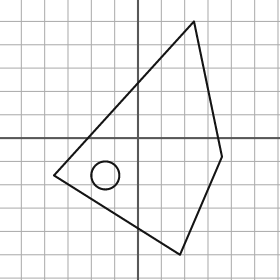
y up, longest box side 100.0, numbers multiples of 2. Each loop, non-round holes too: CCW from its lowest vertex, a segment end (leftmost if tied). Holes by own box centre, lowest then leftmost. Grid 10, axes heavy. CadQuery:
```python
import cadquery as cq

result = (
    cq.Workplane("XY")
    .moveTo(18.0, -50.0)
    .lineTo(36.0, -8.0)
    .lineTo(24.0, 50.0)
    .lineTo(-36.0, -16.0)
    .close()
    .moveTo(-14.0, -16.0)
    .circle(6.0)
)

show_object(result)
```